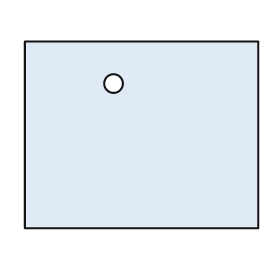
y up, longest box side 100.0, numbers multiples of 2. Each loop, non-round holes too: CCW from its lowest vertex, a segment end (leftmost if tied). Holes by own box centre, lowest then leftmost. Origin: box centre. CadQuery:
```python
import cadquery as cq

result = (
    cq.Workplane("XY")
    .moveTo(-50.0, -40.0)
    .lineTo(50.0, -40.0)
    .lineTo(50.0, 40.0)
    .lineTo(-50.0, 40.0)
    .close()
    .moveTo(-12.0, 22.0)
    .circle(4.0)
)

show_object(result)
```